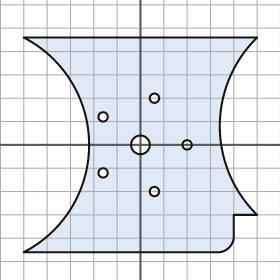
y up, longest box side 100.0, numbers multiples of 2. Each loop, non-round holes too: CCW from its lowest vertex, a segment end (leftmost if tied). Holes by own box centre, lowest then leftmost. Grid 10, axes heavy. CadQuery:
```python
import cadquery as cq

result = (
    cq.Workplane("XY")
    .moveTo(-50.0, -46.0)
    .lineTo(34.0, -46.0)
    .threePointArc((38.0, -44.0), (40.0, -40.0))
    .lineTo(40.0, -30.0)
    .lineTo(50.0, -30.0)
    .threePointArc((34.0, 8.0), (50.0, 46.0))
    .lineTo(-50.0, 46.0)
    .threePointArc((-22.0, 0.0), (-50.0, -46.0))
    .close()
    .moveTo(6.0, -20.0)
    .circle(2.0)
    .moveTo(-16.0, -12.0)
    .circle(2.0)
    .moveTo(0.0, 0.0)
    .circle(4.0)
    .moveTo(20.0, 0.0)
    .circle(2.0)
    .moveTo(-16.0, 12.0)
    .circle(2.0)
    .moveTo(6.0, 20.0)
    .circle(2.0)
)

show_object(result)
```